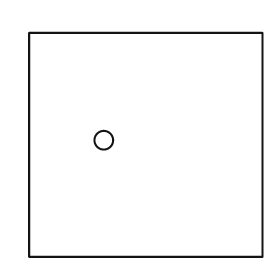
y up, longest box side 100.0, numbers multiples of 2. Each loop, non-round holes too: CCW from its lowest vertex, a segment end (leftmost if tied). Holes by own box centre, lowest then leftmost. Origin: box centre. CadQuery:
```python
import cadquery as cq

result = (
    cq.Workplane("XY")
    .moveTo(-50.0, -48.0)
    .lineTo(50.0, -48.0)
    .lineTo(50.0, 48.0)
    .lineTo(-50.0, 48.0)
    .close()
    .moveTo(-18.0, 2.0)
    .circle(4.0)
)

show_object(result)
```